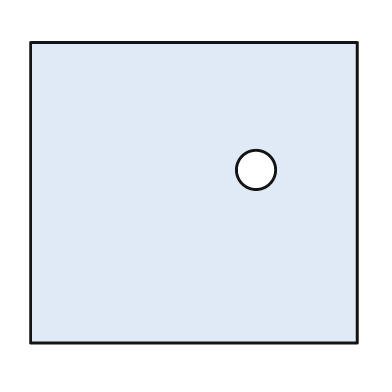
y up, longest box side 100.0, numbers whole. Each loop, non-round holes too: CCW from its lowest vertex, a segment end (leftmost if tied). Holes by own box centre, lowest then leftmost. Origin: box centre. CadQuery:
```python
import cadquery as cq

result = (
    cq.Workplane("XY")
    .moveTo(-50.0, -46.0)
    .lineTo(50.0, -46.0)
    .lineTo(50.0, 46.0)
    .lineTo(-50.0, 46.0)
    .close()
    .moveTo(19.0, 7.0)
    .circle(6.0)
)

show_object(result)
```